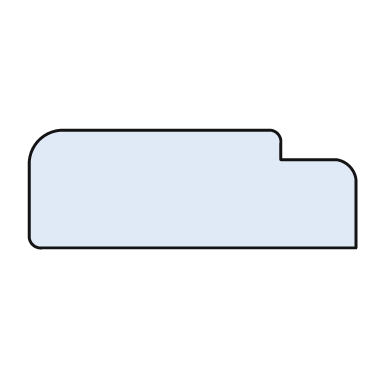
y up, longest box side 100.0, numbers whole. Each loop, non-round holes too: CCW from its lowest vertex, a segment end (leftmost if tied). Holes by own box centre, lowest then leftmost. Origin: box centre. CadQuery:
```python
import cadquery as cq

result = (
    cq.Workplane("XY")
    .moveTo(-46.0, -18.0)
    .lineTo(50.0, -18.0)
    .lineTo(50.0, 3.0)
    .threePointArc((48.0, 7.0), (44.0, 9.0))
    .lineTo(27.0, 9.0)
    .lineTo(27.0, 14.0)
    .threePointArc((26.0, 17.0), (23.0, 18.0))
    .lineTo(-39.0, 18.0)
    .threePointArc((-47.0, 15.0), (-50.0, 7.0))
    .lineTo(-50.0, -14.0)
    .threePointArc((-49.0, -17.0), (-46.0, -18.0))
    .close()
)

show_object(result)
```